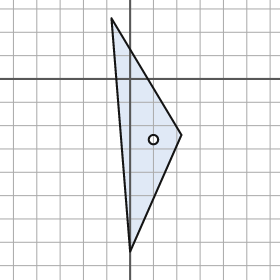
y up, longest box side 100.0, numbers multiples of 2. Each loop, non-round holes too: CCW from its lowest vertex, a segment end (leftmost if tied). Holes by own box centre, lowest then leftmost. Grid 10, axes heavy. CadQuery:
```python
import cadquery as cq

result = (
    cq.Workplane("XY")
    .moveTo(0.0, -74.0)
    .lineTo(22.0, -24.0)
    .lineTo(-8.0, 26.0)
    .close()
    .moveTo(10.0, -26.0)
    .circle(2.0)
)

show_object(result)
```